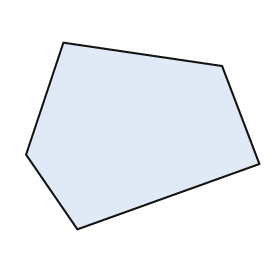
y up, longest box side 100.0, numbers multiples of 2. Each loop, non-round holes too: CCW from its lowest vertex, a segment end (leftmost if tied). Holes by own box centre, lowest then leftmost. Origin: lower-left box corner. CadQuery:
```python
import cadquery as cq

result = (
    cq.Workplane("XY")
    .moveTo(22.0, 0.0)
    .lineTo(100.0, 28.0)
    .lineTo(84.0, 70.0)
    .lineTo(16.0, 80.0)
    .lineTo(0.0, 32.0)
    .close()
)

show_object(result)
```